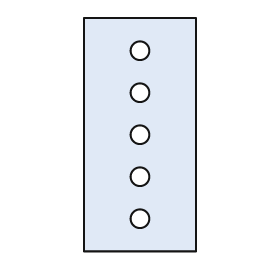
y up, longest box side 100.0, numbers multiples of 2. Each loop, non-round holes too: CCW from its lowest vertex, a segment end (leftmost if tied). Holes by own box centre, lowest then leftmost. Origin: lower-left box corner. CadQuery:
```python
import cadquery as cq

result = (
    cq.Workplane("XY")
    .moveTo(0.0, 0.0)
    .lineTo(48.0, 0.0)
    .lineTo(48.0, 100.0)
    .lineTo(0.0, 100.0)
    .close()
    .moveTo(24.0, 14.0)
    .circle(4.0)
    .moveTo(24.0, 32.0)
    .circle(4.0)
    .moveTo(24.0, 50.0)
    .circle(4.0)
    .moveTo(24.0, 68.0)
    .circle(4.0)
    .moveTo(24.0, 86.0)
    .circle(4.0)
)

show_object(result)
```